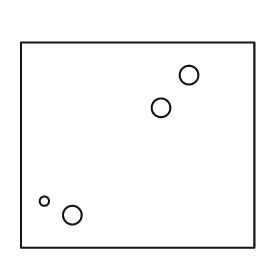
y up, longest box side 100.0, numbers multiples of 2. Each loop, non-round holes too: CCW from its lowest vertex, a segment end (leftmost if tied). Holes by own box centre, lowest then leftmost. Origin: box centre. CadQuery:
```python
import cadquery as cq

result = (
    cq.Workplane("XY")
    .moveTo(-50.0, -44.0)
    .lineTo(50.0, -44.0)
    .lineTo(50.0, 44.0)
    .lineTo(-50.0, 44.0)
    .close()
    .moveTo(-28.0, -30.0)
    .circle(4.0)
    .moveTo(-40.0, -24.0)
    .circle(2.0)
    .moveTo(10.0, 16.0)
    .circle(4.0)
    .moveTo(22.0, 30.0)
    .circle(4.0)
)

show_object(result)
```